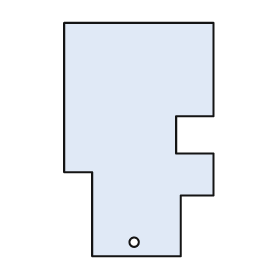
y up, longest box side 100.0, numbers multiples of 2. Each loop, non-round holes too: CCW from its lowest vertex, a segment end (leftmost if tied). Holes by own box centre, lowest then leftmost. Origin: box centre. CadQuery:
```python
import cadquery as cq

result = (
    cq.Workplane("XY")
    .moveTo(-20.0, -50.0)
    .lineTo(18.0, -50.0)
    .lineTo(18.0, -24.0)
    .lineTo(32.0, -24.0)
    .lineTo(32.0, -6.0)
    .lineTo(16.0, -6.0)
    .lineTo(16.0, 10.0)
    .lineTo(32.0, 10.0)
    .lineTo(32.0, 50.0)
    .lineTo(-32.0, 50.0)
    .lineTo(-32.0, -14.0)
    .lineTo(-20.0, -14.0)
    .close()
    .moveTo(-2.0, -44.0)
    .circle(2.0)
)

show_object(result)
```